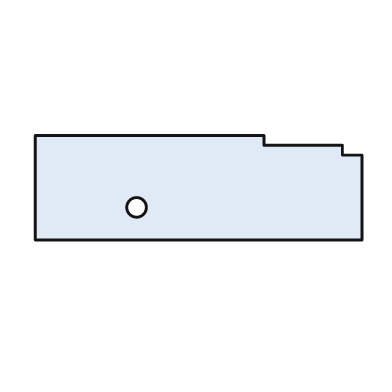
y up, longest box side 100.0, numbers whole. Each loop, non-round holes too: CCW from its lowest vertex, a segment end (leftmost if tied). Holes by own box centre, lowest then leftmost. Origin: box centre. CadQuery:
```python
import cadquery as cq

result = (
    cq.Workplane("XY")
    .moveTo(-50.0, -16.0)
    .lineTo(50.0, -16.0)
    .lineTo(50.0, 10.0)
    .lineTo(44.0, 10.0)
    .lineTo(44.0, 13.0)
    .lineTo(20.0, 13.0)
    .lineTo(20.0, 16.0)
    .lineTo(-50.0, 16.0)
    .close()
    .moveTo(-19.0, -6.0)
    .circle(3.0)
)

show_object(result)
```